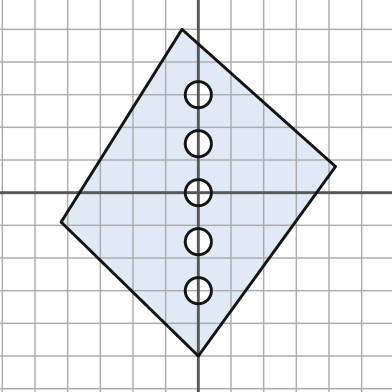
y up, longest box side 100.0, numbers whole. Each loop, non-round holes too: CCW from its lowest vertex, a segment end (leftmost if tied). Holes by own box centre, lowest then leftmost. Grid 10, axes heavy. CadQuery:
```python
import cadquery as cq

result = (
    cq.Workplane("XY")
    .moveTo(0.0, -50.0)
    .lineTo(42.0, 8.0)
    .lineTo(-5.0, 50.0)
    .lineTo(-42.0, -9.0)
    .close()
    .moveTo(0.0, -30.0)
    .circle(4.0)
    .moveTo(0.0, -15.0)
    .circle(4.0)
    .moveTo(0.0, 0.0)
    .circle(4.0)
    .moveTo(0.0, 15.0)
    .circle(4.0)
    .moveTo(0.0, 30.0)
    .circle(4.0)
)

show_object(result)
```